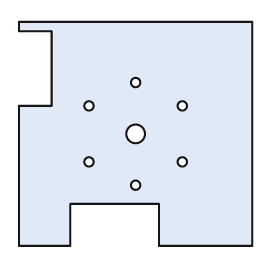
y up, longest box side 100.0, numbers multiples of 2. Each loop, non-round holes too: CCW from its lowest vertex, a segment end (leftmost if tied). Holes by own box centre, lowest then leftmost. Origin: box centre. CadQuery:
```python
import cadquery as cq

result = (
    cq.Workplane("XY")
    .moveTo(-50.0, -48.0)
    .lineTo(-28.0, -48.0)
    .lineTo(-28.0, -30.0)
    .lineTo(10.0, -30.0)
    .lineTo(10.0, -48.0)
    .lineTo(50.0, -48.0)
    .lineTo(50.0, 48.0)
    .lineTo(-50.0, 48.0)
    .lineTo(-50.0, 44.0)
    .lineTo(-36.0, 44.0)
    .lineTo(-36.0, 12.0)
    .lineTo(-50.0, 12.0)
    .close()
    .moveTo(0.0, -22.0)
    .circle(2.0)
    .moveTo(-20.0, -12.0)
    .circle(2.0)
    .moveTo(20.0, -12.0)
    .circle(2.0)
    .moveTo(0.0, 0.0)
    .circle(4.0)
    .moveTo(-20.0, 12.0)
    .circle(2.0)
    .moveTo(20.0, 12.0)
    .circle(2.0)
    .moveTo(0.0, 22.0)
    .circle(2.0)
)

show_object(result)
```